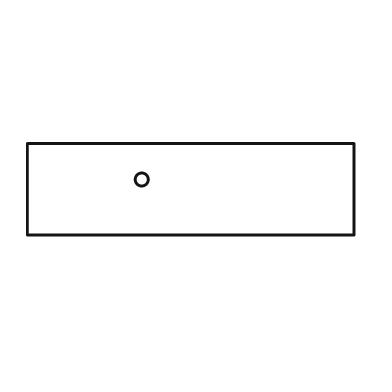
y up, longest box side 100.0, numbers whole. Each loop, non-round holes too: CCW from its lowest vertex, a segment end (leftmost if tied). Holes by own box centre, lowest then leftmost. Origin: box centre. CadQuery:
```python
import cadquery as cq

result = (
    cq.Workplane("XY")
    .moveTo(-50.0, -14.0)
    .lineTo(50.0, -14.0)
    .lineTo(50.0, 14.0)
    .lineTo(-50.0, 14.0)
    .close()
    .moveTo(-15.0, 3.0)
    .circle(2.0)
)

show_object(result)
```